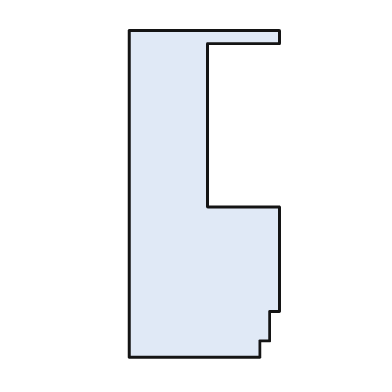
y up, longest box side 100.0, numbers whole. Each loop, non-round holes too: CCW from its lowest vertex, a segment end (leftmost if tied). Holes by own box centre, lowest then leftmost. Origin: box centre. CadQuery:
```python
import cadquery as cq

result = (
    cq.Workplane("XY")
    .moveTo(-23.0, -50.0)
    .lineTo(17.0, -50.0)
    .lineTo(17.0, -45.0)
    .lineTo(20.0, -45.0)
    .lineTo(20.0, -36.0)
    .lineTo(23.0, -36.0)
    .lineTo(23.0, -4.0)
    .lineTo(1.0, -4.0)
    .lineTo(1.0, 46.0)
    .lineTo(23.0, 46.0)
    .lineTo(23.0, 50.0)
    .lineTo(-23.0, 50.0)
    .close()
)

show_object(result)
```